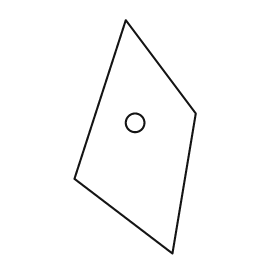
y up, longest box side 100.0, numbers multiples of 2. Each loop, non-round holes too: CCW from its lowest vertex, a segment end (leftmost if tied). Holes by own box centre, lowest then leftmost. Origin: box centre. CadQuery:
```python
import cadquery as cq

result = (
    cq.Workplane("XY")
    .moveTo(16.0, -50.0)
    .lineTo(26.0, 10.0)
    .lineTo(-4.0, 50.0)
    .lineTo(-26.0, -18.0)
    .close()
    .moveTo(0.0, 6.0)
    .circle(4.0)
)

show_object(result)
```